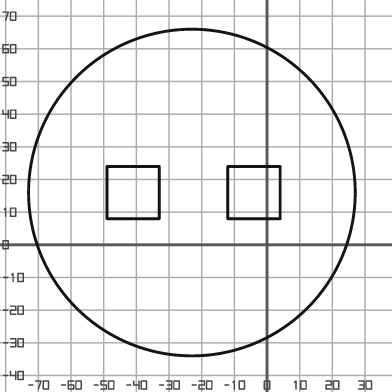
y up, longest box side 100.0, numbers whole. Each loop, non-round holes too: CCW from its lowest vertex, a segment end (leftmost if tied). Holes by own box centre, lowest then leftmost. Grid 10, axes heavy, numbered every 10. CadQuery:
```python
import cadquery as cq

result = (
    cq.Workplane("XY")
    .moveTo(-23.0, 16.0)
    .circle(50.0)
    .moveTo(-49.0, 8.0)
    .lineTo(-33.0, 8.0)
    .lineTo(-33.0, 24.0)
    .lineTo(-49.0, 24.0)
    .close()
    .moveTo(-12.0, 8.0)
    .lineTo(4.0, 8.0)
    .lineTo(4.0, 24.0)
    .lineTo(-12.0, 24.0)
    .close()
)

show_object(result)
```